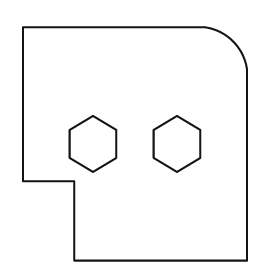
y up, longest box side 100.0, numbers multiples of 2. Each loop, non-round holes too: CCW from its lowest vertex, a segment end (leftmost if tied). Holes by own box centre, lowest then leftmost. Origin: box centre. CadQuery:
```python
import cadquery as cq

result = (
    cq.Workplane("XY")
    .moveTo(-26.0, -50.0)
    .lineTo(48.0, -50.0)
    .lineTo(48.0, 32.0)
    .threePointArc((42.0, 44.0), (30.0, 50.0))
    .lineTo(-48.0, 50.0)
    .lineTo(-48.0, -16.0)
    .lineTo(-26.0, -16.0)
    .close()
    .moveTo(-18.0, -12.0)
    .lineTo(-8.0, -6.0)
    .lineTo(-8.0, 6.0)
    .lineTo(-18.0, 12.0)
    .lineTo(-28.0, 6.0)
    .lineTo(-28.0, -6.0)
    .close()
    .moveTo(18.0, -12.0)
    .lineTo(28.0, -6.0)
    .lineTo(28.0, 6.0)
    .lineTo(18.0, 12.0)
    .lineTo(8.0, 6.0)
    .lineTo(8.0, -6.0)
    .close()
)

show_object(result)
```